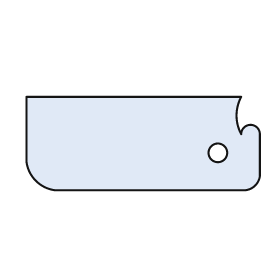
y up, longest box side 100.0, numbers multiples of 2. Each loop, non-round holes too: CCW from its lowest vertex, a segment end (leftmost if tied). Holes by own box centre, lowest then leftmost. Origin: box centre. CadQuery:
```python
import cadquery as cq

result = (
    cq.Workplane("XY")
    .moveTo(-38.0, -20.0)
    .lineTo(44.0, -20.0)
    .threePointArc((48.0, -18.0), (50.0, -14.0))
    .lineTo(50.0, 4.0)
    .threePointArc((46.0, 8.0), (42.0, 4.0))
    .threePointArc((40.0, 12.0), (42.0, 20.0))
    .lineTo(-50.0, 20.0)
    .lineTo(-50.0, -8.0)
    .threePointArc((-46.0, -16.0), (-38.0, -20.0))
    .close()
    .moveTo(32.0, -4.0)
    .circle(4.0)
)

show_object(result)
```